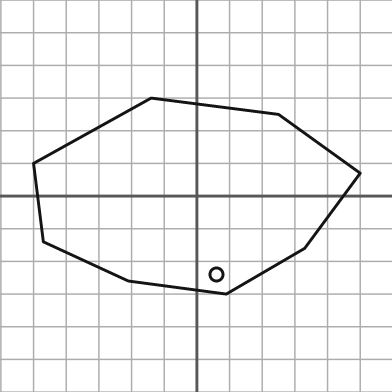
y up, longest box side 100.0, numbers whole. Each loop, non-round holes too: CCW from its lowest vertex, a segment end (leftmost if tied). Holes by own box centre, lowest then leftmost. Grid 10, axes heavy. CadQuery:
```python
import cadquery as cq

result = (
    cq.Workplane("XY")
    .moveTo(9.0, -30.0)
    .lineTo(33.0, -16.0)
    .lineTo(50.0, 7.0)
    .lineTo(25.0, 25.0)
    .lineTo(-14.0, 30.0)
    .lineTo(-50.0, 10.0)
    .lineTo(-47.0, -14.0)
    .lineTo(-21.0, -26.0)
    .close()
    .moveTo(6.0, -24.0)
    .circle(2.0)
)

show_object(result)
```